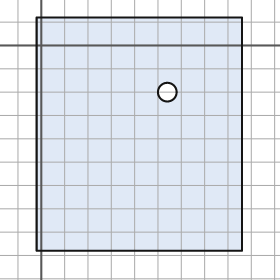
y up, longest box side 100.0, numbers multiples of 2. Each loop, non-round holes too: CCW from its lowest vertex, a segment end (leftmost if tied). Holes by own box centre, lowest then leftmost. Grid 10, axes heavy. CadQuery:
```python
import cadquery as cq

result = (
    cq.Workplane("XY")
    .moveTo(-2.0, -88.0)
    .lineTo(86.0, -88.0)
    .lineTo(86.0, 12.0)
    .lineTo(-2.0, 12.0)
    .close()
    .moveTo(54.0, -20.0)
    .circle(4.0)
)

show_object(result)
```